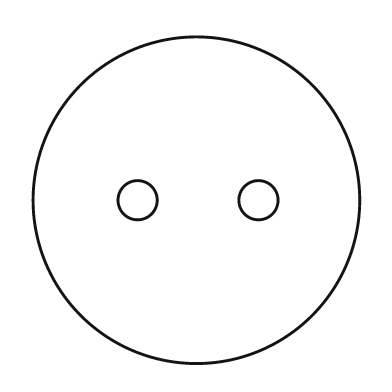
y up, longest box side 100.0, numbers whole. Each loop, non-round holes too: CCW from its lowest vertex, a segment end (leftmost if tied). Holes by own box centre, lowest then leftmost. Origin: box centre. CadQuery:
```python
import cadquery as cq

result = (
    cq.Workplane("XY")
    .moveTo(0.0, 0.0)
    .circle(50.0)
    .moveTo(-18.0, 0.0)
    .circle(6.0)
    .moveTo(19.0, 0.0)
    .circle(6.0)
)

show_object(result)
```